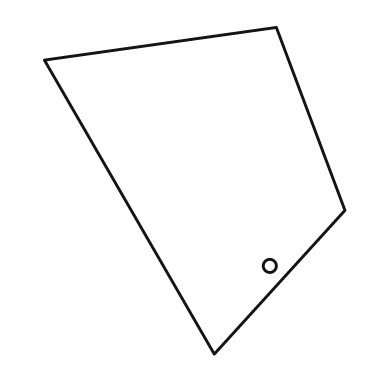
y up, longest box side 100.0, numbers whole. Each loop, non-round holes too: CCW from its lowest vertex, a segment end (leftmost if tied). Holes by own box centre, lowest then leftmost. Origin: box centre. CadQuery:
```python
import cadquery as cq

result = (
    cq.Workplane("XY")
    .moveTo(6.0, -50.0)
    .lineTo(46.0, -6.0)
    .lineTo(25.0, 50.0)
    .lineTo(-46.0, 40.0)
    .close()
    .moveTo(23.0, -23.0)
    .circle(2.0)
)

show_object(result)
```